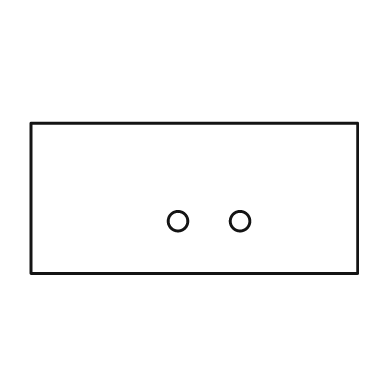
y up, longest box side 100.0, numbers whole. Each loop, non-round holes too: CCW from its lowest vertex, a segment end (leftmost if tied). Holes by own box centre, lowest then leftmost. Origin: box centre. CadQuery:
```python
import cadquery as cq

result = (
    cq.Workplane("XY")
    .moveTo(-50.0, -23.0)
    .lineTo(50.0, -23.0)
    .lineTo(50.0, 23.0)
    .lineTo(-50.0, 23.0)
    .close()
    .moveTo(-5.0, -7.0)
    .circle(3.0)
    .moveTo(14.0, -7.0)
    .circle(3.0)
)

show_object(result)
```